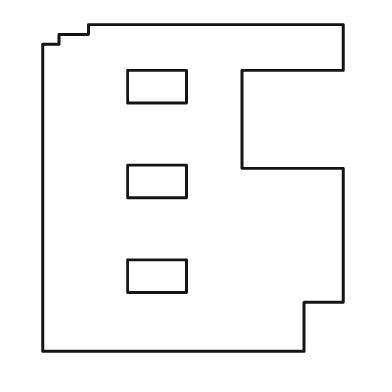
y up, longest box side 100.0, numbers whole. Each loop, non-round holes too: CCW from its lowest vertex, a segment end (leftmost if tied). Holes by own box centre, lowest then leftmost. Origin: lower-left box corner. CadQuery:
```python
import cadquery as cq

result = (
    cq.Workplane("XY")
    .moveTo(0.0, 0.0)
    .lineTo(80.0, 0.0)
    .lineTo(80.0, 15.0)
    .lineTo(92.0, 15.0)
    .lineTo(92.0, 56.0)
    .lineTo(61.0, 56.0)
    .lineTo(61.0, 86.0)
    .lineTo(92.0, 86.0)
    .lineTo(92.0, 100.0)
    .lineTo(14.0, 100.0)
    .lineTo(14.0, 97.0)
    .lineTo(5.0, 97.0)
    .lineTo(5.0, 94.0)
    .lineTo(0.0, 94.0)
    .close()
    .moveTo(26.0, 18.0)
    .lineTo(44.0, 18.0)
    .lineTo(44.0, 28.0)
    .lineTo(26.0, 28.0)
    .close()
    .moveTo(26.0, 47.0)
    .lineTo(44.0, 47.0)
    .lineTo(44.0, 57.0)
    .lineTo(26.0, 57.0)
    .close()
    .moveTo(26.0, 76.0)
    .lineTo(44.0, 76.0)
    .lineTo(44.0, 86.0)
    .lineTo(26.0, 86.0)
    .close()
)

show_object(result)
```